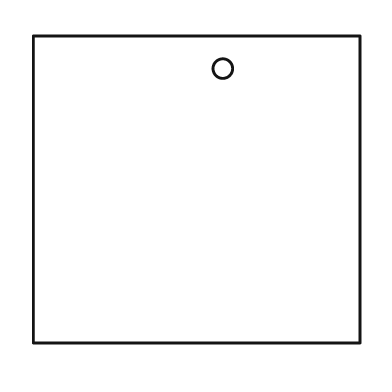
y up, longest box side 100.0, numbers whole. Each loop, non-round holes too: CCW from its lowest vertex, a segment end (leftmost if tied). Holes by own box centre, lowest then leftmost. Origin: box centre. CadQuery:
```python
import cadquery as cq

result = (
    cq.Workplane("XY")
    .moveTo(-50.0, -47.0)
    .lineTo(50.0, -47.0)
    .lineTo(50.0, 47.0)
    .lineTo(-50.0, 47.0)
    .close()
    .moveTo(8.0, 37.0)
    .circle(3.0)
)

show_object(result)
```